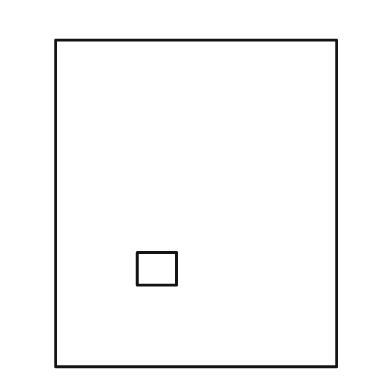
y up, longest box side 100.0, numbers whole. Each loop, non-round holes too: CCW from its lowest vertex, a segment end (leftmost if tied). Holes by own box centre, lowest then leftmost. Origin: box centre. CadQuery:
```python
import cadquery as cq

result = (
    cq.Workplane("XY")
    .moveTo(-43.0, -50.0)
    .lineTo(43.0, -50.0)
    .lineTo(43.0, 50.0)
    .lineTo(-43.0, 50.0)
    .close()
    .moveTo(-18.0, -25.0)
    .lineTo(-6.0, -25.0)
    .lineTo(-6.0, -15.0)
    .lineTo(-18.0, -15.0)
    .close()
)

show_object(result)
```